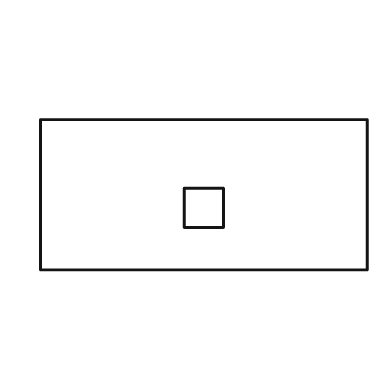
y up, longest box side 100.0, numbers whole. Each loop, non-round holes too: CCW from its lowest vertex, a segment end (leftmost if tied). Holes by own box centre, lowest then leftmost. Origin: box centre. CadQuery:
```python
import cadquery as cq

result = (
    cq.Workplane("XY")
    .moveTo(-50.0, -23.0)
    .lineTo(50.0, -23.0)
    .lineTo(50.0, 23.0)
    .lineTo(-50.0, 23.0)
    .close()
    .moveTo(-6.0, -10.0)
    .lineTo(6.0, -10.0)
    .lineTo(6.0, 2.0)
    .lineTo(-6.0, 2.0)
    .close()
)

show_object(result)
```